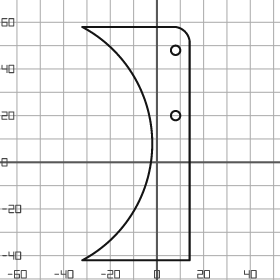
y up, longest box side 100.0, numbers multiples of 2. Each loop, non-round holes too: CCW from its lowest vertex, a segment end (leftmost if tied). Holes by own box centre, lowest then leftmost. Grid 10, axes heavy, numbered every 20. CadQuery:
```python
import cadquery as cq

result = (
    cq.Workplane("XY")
    .moveTo(-32.0, -42.0)
    .lineTo(14.0, -42.0)
    .lineTo(14.0, 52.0)
    .threePointArc((12.0, 56.0), (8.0, 58.0))
    .lineTo(-32.0, 58.0)
    .threePointArc((-2.0, 8.0), (-32.0, -42.0))
    .close()
    .moveTo(8.0, 20.0)
    .circle(2.0)
    .moveTo(8.0, 48.0)
    .circle(2.0)
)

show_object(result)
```